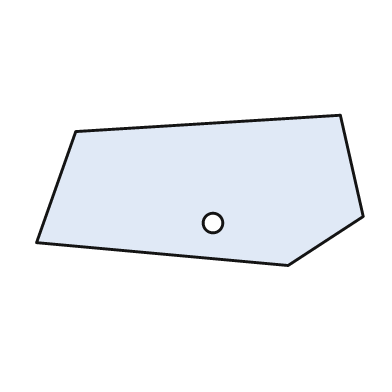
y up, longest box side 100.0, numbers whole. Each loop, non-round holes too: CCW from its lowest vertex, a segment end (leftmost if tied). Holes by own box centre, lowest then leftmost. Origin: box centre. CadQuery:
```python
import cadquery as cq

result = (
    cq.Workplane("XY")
    .moveTo(27.0, -23.0)
    .lineTo(50.0, -8.0)
    .lineTo(43.0, 23.0)
    .lineTo(-38.0, 18.0)
    .lineTo(-50.0, -16.0)
    .close()
    .moveTo(4.0, -10.0)
    .circle(3.0)
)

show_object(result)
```